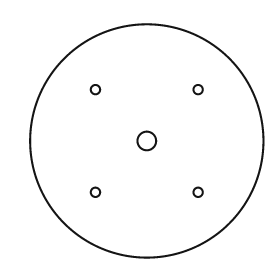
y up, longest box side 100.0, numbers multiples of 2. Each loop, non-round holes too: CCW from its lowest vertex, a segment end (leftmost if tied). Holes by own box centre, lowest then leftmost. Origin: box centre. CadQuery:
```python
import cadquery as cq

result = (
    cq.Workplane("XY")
    .moveTo(0.0, 0.0)
    .circle(50.0)
    .moveTo(-22.0, -22.0)
    .circle(2.0)
    .moveTo(22.0, -22.0)
    .circle(2.0)
    .moveTo(0.0, 0.0)
    .circle(4.0)
    .moveTo(-22.0, 22.0)
    .circle(2.0)
    .moveTo(22.0, 22.0)
    .circle(2.0)
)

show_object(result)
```